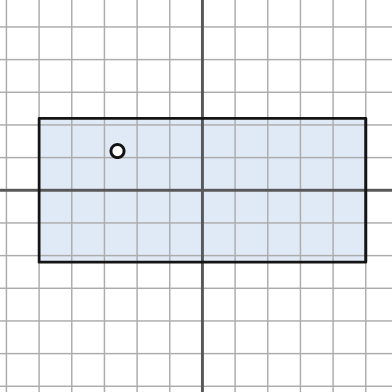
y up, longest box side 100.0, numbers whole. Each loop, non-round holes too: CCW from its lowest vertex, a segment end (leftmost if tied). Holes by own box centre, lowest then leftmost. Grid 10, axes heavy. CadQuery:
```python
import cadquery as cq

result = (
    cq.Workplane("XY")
    .moveTo(-50.0, -22.0)
    .lineTo(50.0, -22.0)
    .lineTo(50.0, 22.0)
    .lineTo(-50.0, 22.0)
    .close()
    .moveTo(-26.0, 12.0)
    .circle(2.0)
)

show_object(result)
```